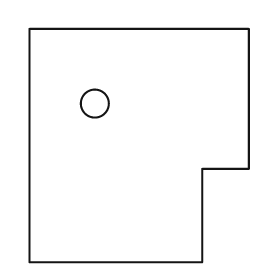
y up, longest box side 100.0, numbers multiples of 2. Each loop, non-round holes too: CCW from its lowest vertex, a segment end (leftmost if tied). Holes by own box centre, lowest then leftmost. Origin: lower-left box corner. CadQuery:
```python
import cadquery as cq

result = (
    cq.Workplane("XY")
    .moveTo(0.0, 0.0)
    .lineTo(74.0, 0.0)
    .lineTo(74.0, 40.0)
    .lineTo(94.0, 40.0)
    .lineTo(94.0, 100.0)
    .lineTo(0.0, 100.0)
    .close()
    .moveTo(28.0, 68.0)
    .circle(6.0)
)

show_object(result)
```